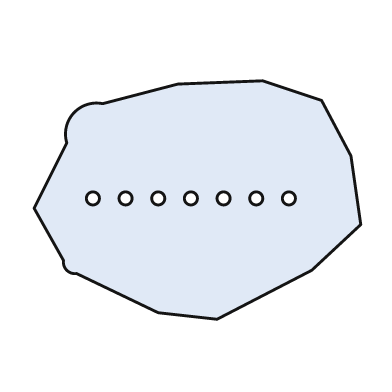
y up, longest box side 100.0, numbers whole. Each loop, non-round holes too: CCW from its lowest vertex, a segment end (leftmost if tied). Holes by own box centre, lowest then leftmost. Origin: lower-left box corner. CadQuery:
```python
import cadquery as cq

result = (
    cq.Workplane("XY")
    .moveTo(56.0, 0.0)
    .lineTo(85.0, 15.0)
    .lineTo(100.0, 29.0)
    .lineTo(97.0, 50.0)
    .lineTo(88.0, 67.0)
    .lineTo(70.0, 73.0)
    .lineTo(44.0, 72.0)
    .lineTo(21.0, 66.0)
    .threePointArc((12.0, 63.0), (10.0, 54.0))
    .lineTo(0.0, 34.0)
    .lineTo(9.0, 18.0)
    .threePointArc((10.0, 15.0), (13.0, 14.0))
    .lineTo(38.0, 2.0)
    .close()
    .moveTo(18.0, 37.0)
    .circle(2.0)
    .moveTo(28.0, 37.0)
    .circle(2.0)
    .moveTo(38.0, 37.0)
    .circle(2.0)
    .moveTo(48.0, 37.0)
    .circle(2.0)
    .moveTo(58.0, 37.0)
    .circle(2.0)
    .moveTo(68.0, 37.0)
    .circle(2.0)
    .moveTo(78.0, 37.0)
    .circle(2.0)
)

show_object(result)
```